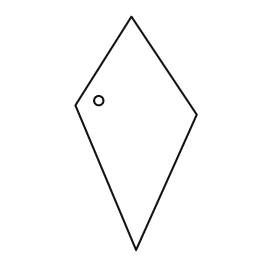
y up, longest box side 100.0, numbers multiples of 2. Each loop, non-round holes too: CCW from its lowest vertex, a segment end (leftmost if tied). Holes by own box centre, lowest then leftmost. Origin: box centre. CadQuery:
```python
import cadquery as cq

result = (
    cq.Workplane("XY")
    .moveTo(0.0, -50.0)
    .lineTo(26.0, 8.0)
    .lineTo(-2.0, 50.0)
    .lineTo(-26.0, 12.0)
    .close()
    .moveTo(-16.0, 14.0)
    .circle(2.0)
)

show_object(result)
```